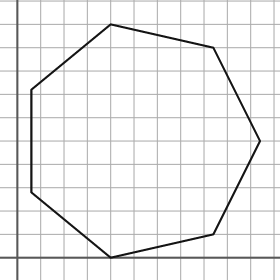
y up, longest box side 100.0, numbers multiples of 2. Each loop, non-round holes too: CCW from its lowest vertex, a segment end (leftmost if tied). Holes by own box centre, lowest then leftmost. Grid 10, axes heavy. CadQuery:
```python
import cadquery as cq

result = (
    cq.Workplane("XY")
    .moveTo(40.0, 0.0)
    .lineTo(84.0, 10.0)
    .lineTo(104.0, 50.0)
    .lineTo(84.0, 90.0)
    .lineTo(40.0, 100.0)
    .lineTo(6.0, 72.0)
    .lineTo(6.0, 28.0)
    .close()
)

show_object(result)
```